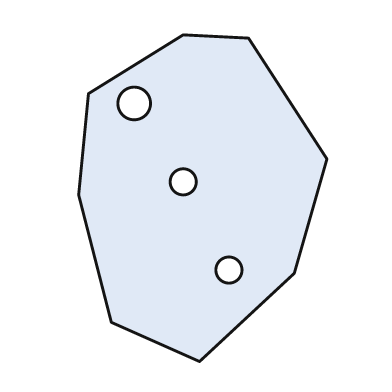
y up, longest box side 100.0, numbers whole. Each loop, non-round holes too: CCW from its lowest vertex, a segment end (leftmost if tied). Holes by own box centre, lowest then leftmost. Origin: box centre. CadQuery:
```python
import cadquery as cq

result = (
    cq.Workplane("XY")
    .moveTo(-1.0, -50.0)
    .lineTo(28.0, -23.0)
    .lineTo(38.0, 12.0)
    .lineTo(14.0, 49.0)
    .lineTo(-6.0, 50.0)
    .lineTo(-35.0, 32.0)
    .lineTo(-38.0, 1.0)
    .lineTo(-28.0, -38.0)
    .close()
    .moveTo(8.0, -22.0)
    .circle(4.0)
    .moveTo(-6.0, 5.0)
    .circle(4.0)
    .moveTo(-21.0, 29.0)
    .circle(5.0)
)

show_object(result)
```